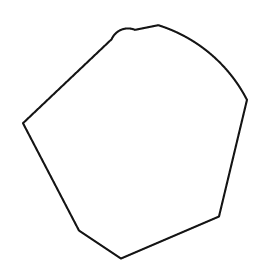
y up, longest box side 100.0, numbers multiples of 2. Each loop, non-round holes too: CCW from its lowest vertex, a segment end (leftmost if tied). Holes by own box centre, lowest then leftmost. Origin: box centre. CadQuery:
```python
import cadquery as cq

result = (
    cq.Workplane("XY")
    .moveTo(-6.0, -50.0)
    .lineTo(36.0, -32.0)
    .lineTo(48.0, 18.0)
    .threePointArc((32.0, 38.0), (10.0, 50.0))
    .lineTo(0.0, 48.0)
    .threePointArc((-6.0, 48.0), (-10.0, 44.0))
    .lineTo(-48.0, 8.0)
    .lineTo(-24.0, -38.0)
    .close()
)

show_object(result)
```